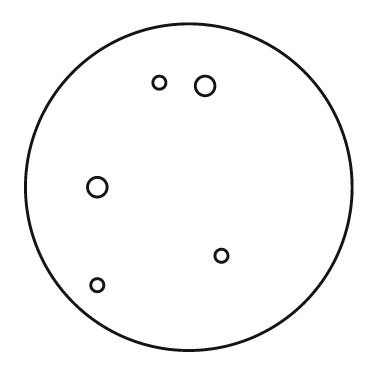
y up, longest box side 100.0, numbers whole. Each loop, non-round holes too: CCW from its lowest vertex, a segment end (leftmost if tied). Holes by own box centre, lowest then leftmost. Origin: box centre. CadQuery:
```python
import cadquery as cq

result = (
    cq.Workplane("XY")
    .moveTo(0.0, 0.0)
    .circle(50.0)
    .moveTo(-28.0, -30.0)
    .circle(2.0)
    .moveTo(10.0, -21.0)
    .circle(2.0)
    .moveTo(-28.0, 0.0)
    .circle(3.0)
    .moveTo(5.0, 31.0)
    .circle(3.0)
    .moveTo(-9.0, 32.0)
    .circle(2.0)
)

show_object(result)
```